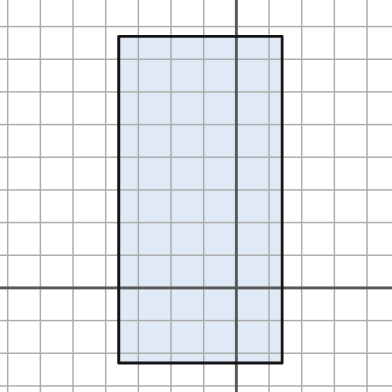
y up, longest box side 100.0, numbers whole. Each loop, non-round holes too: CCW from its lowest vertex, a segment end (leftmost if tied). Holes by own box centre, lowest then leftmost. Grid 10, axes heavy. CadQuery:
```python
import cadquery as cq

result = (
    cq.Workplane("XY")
    .moveTo(-36.0, -23.0)
    .lineTo(14.0, -23.0)
    .lineTo(14.0, 77.0)
    .lineTo(-36.0, 77.0)
    .close()
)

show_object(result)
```